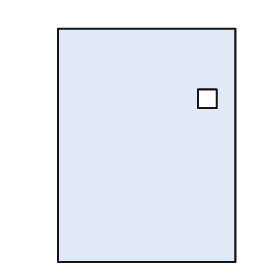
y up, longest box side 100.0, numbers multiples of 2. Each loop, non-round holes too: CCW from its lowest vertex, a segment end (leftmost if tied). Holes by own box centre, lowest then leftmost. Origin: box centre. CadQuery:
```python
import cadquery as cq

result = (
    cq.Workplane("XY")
    .moveTo(-38.0, -50.0)
    .lineTo(38.0, -50.0)
    .lineTo(38.0, 50.0)
    .lineTo(-38.0, 50.0)
    .close()
    .moveTo(22.0, 16.0)
    .lineTo(30.0, 16.0)
    .lineTo(30.0, 24.0)
    .lineTo(22.0, 24.0)
    .close()
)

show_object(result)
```